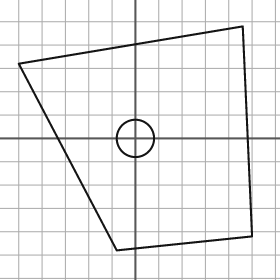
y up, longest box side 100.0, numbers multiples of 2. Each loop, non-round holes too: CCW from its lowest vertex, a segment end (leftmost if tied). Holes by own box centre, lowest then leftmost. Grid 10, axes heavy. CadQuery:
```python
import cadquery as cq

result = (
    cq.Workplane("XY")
    .moveTo(-8.0, -48.0)
    .lineTo(50.0, -42.0)
    .lineTo(46.0, 48.0)
    .lineTo(-50.0, 32.0)
    .close()
    .moveTo(0.0, 0.0)
    .circle(8.0)
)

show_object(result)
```